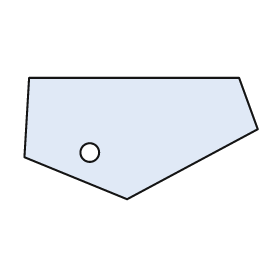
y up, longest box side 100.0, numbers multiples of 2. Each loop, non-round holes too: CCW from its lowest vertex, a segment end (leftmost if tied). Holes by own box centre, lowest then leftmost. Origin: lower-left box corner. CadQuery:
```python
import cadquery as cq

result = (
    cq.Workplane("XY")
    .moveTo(44.0, 0.0)
    .lineTo(100.0, 30.0)
    .lineTo(92.0, 52.0)
    .lineTo(2.0, 52.0)
    .lineTo(0.0, 18.0)
    .close()
    .moveTo(28.0, 20.0)
    .circle(4.0)
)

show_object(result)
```